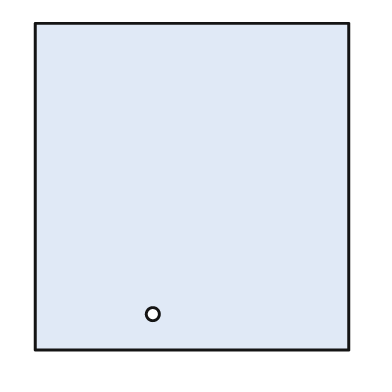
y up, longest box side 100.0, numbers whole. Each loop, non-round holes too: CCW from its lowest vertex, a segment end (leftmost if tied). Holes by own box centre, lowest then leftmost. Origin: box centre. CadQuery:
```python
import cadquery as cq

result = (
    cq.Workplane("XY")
    .moveTo(-48.0, -50.0)
    .lineTo(48.0, -50.0)
    .lineTo(48.0, 50.0)
    .lineTo(-48.0, 50.0)
    .close()
    .moveTo(-12.0, -39.0)
    .circle(2.0)
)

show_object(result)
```